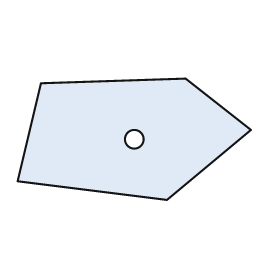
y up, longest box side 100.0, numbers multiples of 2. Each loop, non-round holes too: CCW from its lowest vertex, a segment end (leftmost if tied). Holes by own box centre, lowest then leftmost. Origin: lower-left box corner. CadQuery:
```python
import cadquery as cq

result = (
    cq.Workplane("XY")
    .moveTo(64.0, 0.0)
    .lineTo(100.0, 30.0)
    .lineTo(72.0, 52.0)
    .lineTo(10.0, 50.0)
    .lineTo(0.0, 8.0)
    .close()
    .moveTo(50.0, 26.0)
    .circle(4.0)
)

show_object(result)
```